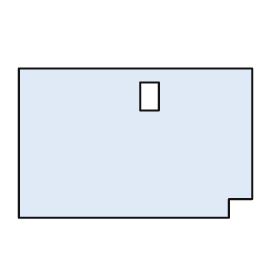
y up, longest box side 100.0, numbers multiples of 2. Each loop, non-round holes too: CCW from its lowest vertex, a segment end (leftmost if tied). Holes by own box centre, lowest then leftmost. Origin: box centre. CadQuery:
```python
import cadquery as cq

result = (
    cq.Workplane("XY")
    .moveTo(-50.0, -32.0)
    .lineTo(40.0, -32.0)
    .lineTo(40.0, -24.0)
    .lineTo(50.0, -24.0)
    .lineTo(50.0, 32.0)
    .lineTo(-50.0, 32.0)
    .close()
    .moveTo(2.0, 14.0)
    .lineTo(10.0, 14.0)
    .lineTo(10.0, 26.0)
    .lineTo(2.0, 26.0)
    .close()
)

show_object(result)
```